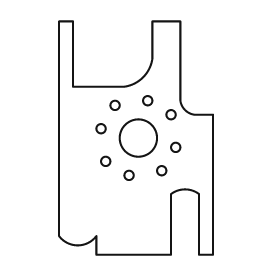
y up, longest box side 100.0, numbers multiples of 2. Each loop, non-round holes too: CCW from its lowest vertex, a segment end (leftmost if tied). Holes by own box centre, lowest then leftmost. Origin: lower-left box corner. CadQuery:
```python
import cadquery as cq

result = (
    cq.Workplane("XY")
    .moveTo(16.0, 0.0)
    .lineTo(48.0, 0.0)
    .lineTo(48.0, 26.0)
    .threePointArc((54.0, 28.0), (60.0, 26.0))
    .lineTo(60.0, 0.0)
    .lineTo(66.0, 0.0)
    .lineTo(66.0, 60.0)
    .lineTo(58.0, 60.0)
    .threePointArc((54.0, 62.0), (52.0, 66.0))
    .lineTo(52.0, 100.0)
    .lineTo(40.0, 100.0)
    .lineTo(40.0, 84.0)
    .threePointArc((36.0, 76.0), (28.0, 72.0))
    .lineTo(6.0, 72.0)
    .lineTo(6.0, 100.0)
    .lineTo(0.0, 100.0)
    .lineTo(0.0, 8.0)
    .threePointArc((8.0, 4.0), (16.0, 8.0))
    .close()
    .moveTo(30.0, 34.0)
    .circle(2.0)
    .moveTo(44.0, 36.0)
    .circle(2.0)
    .moveTo(20.0, 40.0)
    .circle(2.0)
    .moveTo(50.0, 46.0)
    .circle(2.0)
    .moveTo(34.0, 50.0)
    .circle(8.0)
    .moveTo(18.0, 54.0)
    .circle(2.0)
    .moveTo(48.0, 60.0)
    .circle(2.0)
    .moveTo(24.0, 64.0)
    .circle(2.0)
    .moveTo(38.0, 66.0)
    .circle(2.0)
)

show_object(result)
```